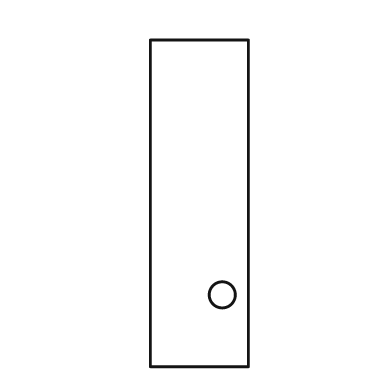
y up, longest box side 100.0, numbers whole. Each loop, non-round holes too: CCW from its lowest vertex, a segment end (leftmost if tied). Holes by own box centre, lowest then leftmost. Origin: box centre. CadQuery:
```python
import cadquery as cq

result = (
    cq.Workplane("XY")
    .moveTo(-15.0, -50.0)
    .lineTo(15.0, -50.0)
    .lineTo(15.0, 50.0)
    .lineTo(-15.0, 50.0)
    .close()
    .moveTo(7.0, -28.0)
    .circle(4.0)
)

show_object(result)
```